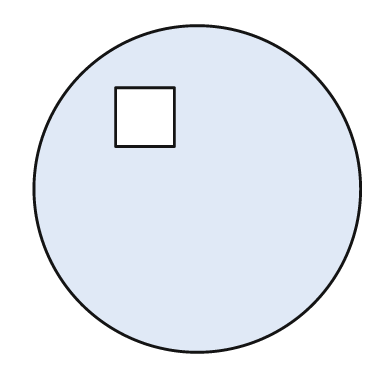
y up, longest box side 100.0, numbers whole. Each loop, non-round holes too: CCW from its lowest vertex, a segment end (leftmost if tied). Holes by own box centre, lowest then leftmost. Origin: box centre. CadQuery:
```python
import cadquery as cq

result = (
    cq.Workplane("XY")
    .moveTo(0.0, 0.0)
    .circle(50.0)
    .moveTo(-25.0, 13.0)
    .lineTo(-7.0, 13.0)
    .lineTo(-7.0, 31.0)
    .lineTo(-25.0, 31.0)
    .close()
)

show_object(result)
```